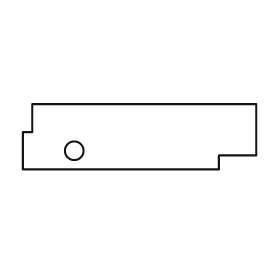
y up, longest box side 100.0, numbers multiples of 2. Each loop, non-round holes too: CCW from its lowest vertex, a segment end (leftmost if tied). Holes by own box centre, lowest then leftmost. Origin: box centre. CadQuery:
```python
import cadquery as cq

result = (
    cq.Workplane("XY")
    .moveTo(-50.0, -14.0)
    .lineTo(34.0, -14.0)
    .lineTo(34.0, -8.0)
    .lineTo(50.0, -8.0)
    .lineTo(50.0, 14.0)
    .lineTo(-46.0, 14.0)
    .lineTo(-46.0, 2.0)
    .lineTo(-50.0, 2.0)
    .close()
    .moveTo(-28.0, -6.0)
    .circle(4.0)
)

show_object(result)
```